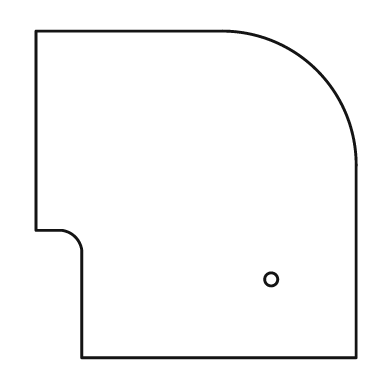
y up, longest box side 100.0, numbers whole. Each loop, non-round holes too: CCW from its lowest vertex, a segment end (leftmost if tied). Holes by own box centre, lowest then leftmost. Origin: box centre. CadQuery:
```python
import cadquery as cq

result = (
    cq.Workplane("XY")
    .moveTo(-35.0, -50.0)
    .lineTo(49.0, -50.0)
    .lineTo(49.0, 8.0)
    .threePointArc((37.0, 38.0), (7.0, 50.0))
    .lineTo(-49.0, 50.0)
    .lineTo(-49.0, -11.0)
    .lineTo(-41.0, -11.0)
    .threePointArc((-37.0, -13.0), (-35.0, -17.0))
    .close()
    .moveTo(23.0, -26.0)
    .circle(2.0)
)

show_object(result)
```